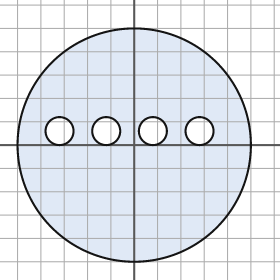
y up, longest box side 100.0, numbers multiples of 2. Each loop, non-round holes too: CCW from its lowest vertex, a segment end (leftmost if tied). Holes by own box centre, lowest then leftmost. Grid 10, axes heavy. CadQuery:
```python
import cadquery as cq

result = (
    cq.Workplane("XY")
    .moveTo(0.0, 0.0)
    .circle(50.0)
    .moveTo(-32.0, 6.0)
    .circle(6.0)
    .moveTo(-12.0, 6.0)
    .circle(6.0)
    .moveTo(8.0, 6.0)
    .circle(6.0)
    .moveTo(28.0, 6.0)
    .circle(6.0)
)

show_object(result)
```